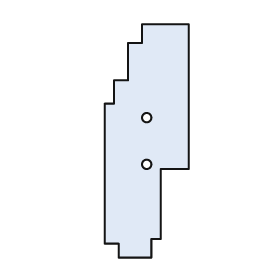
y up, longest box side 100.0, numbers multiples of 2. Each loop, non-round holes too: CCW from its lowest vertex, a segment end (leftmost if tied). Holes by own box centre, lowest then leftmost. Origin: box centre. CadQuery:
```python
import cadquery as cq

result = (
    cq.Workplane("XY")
    .moveTo(-12.0, -50.0)
    .lineTo(2.0, -50.0)
    .lineTo(2.0, -42.0)
    .lineTo(6.0, -42.0)
    .lineTo(6.0, -12.0)
    .lineTo(18.0, -12.0)
    .lineTo(18.0, 50.0)
    .lineTo(-2.0, 50.0)
    .lineTo(-2.0, 42.0)
    .lineTo(-8.0, 42.0)
    .lineTo(-8.0, 26.0)
    .lineTo(-14.0, 26.0)
    .lineTo(-14.0, 16.0)
    .lineTo(-18.0, 16.0)
    .lineTo(-18.0, -44.0)
    .lineTo(-12.0, -44.0)
    .close()
    .moveTo(0.0, -10.0)
    .circle(2.0)
    .moveTo(0.0, 10.0)
    .circle(2.0)
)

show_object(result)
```